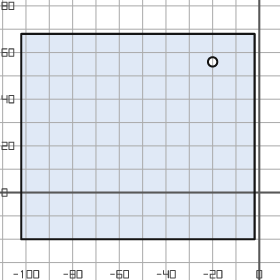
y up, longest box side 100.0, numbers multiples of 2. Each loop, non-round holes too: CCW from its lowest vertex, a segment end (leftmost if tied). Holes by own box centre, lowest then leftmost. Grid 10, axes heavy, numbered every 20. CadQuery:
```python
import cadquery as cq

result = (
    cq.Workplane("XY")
    .moveTo(-102.0, -20.0)
    .lineTo(-2.0, -20.0)
    .lineTo(-2.0, 68.0)
    .lineTo(-102.0, 68.0)
    .close()
    .moveTo(-20.0, 56.0)
    .circle(2.0)
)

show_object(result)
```